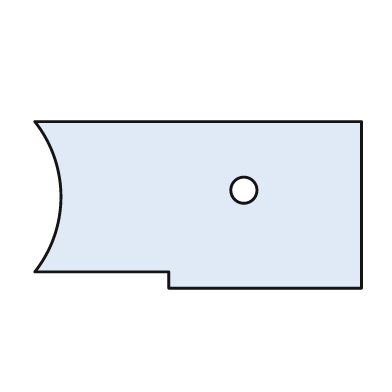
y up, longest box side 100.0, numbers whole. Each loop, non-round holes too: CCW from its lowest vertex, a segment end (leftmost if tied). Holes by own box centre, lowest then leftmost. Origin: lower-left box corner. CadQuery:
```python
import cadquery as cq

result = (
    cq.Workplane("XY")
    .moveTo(41.0, 0.0)
    .lineTo(100.0, 0.0)
    .lineTo(100.0, 51.0)
    .lineTo(0.0, 51.0)
    .threePointArc((8.0, 28.0), (0.0, 5.0))
    .lineTo(41.0, 5.0)
    .close()
    .moveTo(64.0, 30.0)
    .circle(4.0)
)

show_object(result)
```